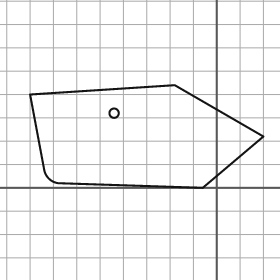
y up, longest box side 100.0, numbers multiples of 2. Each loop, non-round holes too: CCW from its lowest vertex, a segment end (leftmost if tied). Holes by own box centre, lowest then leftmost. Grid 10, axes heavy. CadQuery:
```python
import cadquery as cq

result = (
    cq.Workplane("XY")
    .moveTo(-6.0, 0.0)
    .lineTo(20.0, 22.0)
    .lineTo(-18.0, 44.0)
    .lineTo(-80.0, 40.0)
    .lineTo(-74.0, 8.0)
    .threePointArc((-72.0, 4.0), (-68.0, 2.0))
    .close()
    .moveTo(-44.0, 32.0)
    .circle(2.0)
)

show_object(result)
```